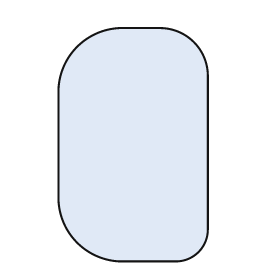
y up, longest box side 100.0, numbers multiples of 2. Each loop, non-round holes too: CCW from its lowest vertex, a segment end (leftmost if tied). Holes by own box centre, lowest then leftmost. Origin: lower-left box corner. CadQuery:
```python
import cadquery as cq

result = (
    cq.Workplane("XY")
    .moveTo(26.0, 0.0)
    .lineTo(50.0, 0.0)
    .threePointArc((60.0, 4.0), (64.0, 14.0))
    .lineTo(64.0, 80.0)
    .threePointArc((58.0, 94.0), (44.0, 100.0))
    .lineTo(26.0, 100.0)
    .threePointArc((8.0, 92.0), (0.0, 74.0))
    .lineTo(0.0, 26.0)
    .threePointArc((8.0, 8.0), (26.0, 0.0))
    .close()
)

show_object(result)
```